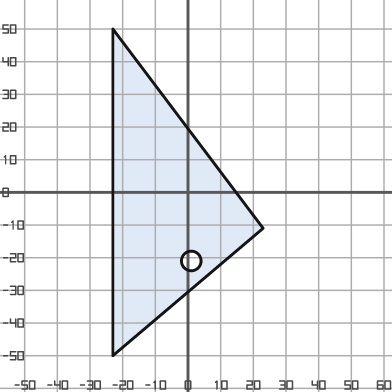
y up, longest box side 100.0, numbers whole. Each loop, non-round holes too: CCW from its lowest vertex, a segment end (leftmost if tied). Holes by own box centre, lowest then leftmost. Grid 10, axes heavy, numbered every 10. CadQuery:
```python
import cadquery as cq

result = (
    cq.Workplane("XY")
    .moveTo(-23.0, -50.0)
    .lineTo(23.0, -11.0)
    .lineTo(-23.0, 50.0)
    .close()
    .moveTo(1.0, -21.0)
    .circle(3.0)
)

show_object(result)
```